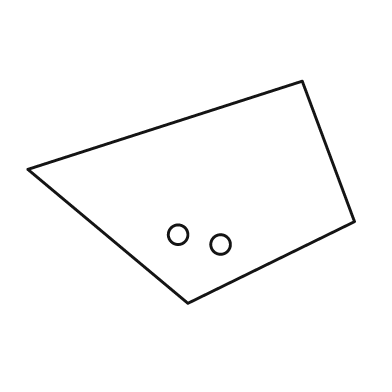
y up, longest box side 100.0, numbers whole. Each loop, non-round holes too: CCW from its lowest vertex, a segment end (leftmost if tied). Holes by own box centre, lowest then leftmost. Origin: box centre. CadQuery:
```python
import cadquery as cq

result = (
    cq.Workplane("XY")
    .moveTo(-1.0, -34.0)
    .lineTo(50.0, -9.0)
    .lineTo(34.0, 34.0)
    .lineTo(-50.0, 7.0)
    .close()
    .moveTo(9.0, -16.0)
    .circle(3.0)
    .moveTo(-4.0, -13.0)
    .circle(3.0)
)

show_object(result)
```